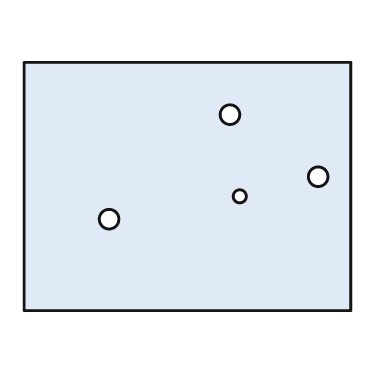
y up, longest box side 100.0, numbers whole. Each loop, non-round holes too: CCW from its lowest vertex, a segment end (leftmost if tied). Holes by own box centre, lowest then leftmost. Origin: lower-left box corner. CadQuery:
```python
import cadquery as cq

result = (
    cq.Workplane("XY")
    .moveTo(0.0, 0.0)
    .lineTo(100.0, 0.0)
    .lineTo(100.0, 76.0)
    .lineTo(0.0, 76.0)
    .close()
    .moveTo(26.0, 28.0)
    .circle(3.0)
    .moveTo(66.0, 35.0)
    .circle(2.0)
    .moveTo(90.0, 41.0)
    .circle(3.0)
    .moveTo(63.0, 60.0)
    .circle(3.0)
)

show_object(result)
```